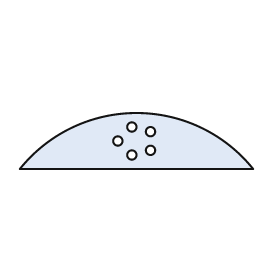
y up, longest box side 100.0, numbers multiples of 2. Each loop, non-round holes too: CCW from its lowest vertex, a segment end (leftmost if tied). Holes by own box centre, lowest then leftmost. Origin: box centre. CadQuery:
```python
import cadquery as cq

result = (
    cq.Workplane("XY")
    .moveTo(-50.0, -12.0)
    .lineTo(50.0, -12.0)
    .threePointArc((0.0, 12.0), (-50.0, -12.0))
    .close()
    .moveTo(-2.0, -6.0)
    .circle(2.0)
    .moveTo(6.0, -4.0)
    .circle(2.0)
    .moveTo(-8.0, 0.0)
    .circle(2.0)
    .moveTo(6.0, 4.0)
    .circle(2.0)
    .moveTo(-2.0, 6.0)
    .circle(2.0)
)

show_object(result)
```